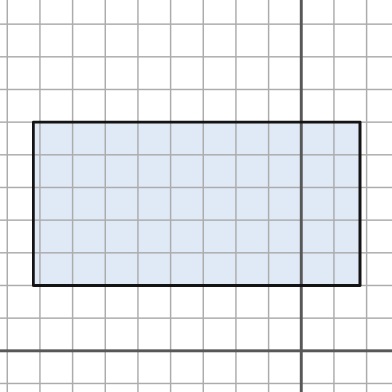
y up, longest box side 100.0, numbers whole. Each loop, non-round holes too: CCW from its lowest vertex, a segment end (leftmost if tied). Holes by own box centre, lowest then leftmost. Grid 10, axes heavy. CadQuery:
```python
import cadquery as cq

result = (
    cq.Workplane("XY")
    .moveTo(-82.0, 20.0)
    .lineTo(18.0, 20.0)
    .lineTo(18.0, 70.0)
    .lineTo(-82.0, 70.0)
    .close()
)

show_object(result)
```